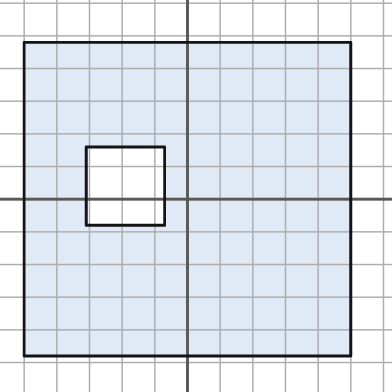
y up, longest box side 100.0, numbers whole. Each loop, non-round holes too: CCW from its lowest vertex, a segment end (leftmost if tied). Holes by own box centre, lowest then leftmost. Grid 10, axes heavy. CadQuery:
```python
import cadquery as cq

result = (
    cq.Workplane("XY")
    .moveTo(-50.0, -48.0)
    .lineTo(50.0, -48.0)
    .lineTo(50.0, 48.0)
    .lineTo(-50.0, 48.0)
    .close()
    .moveTo(-31.0, -8.0)
    .lineTo(-7.0, -8.0)
    .lineTo(-7.0, 16.0)
    .lineTo(-31.0, 16.0)
    .close()
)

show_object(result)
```